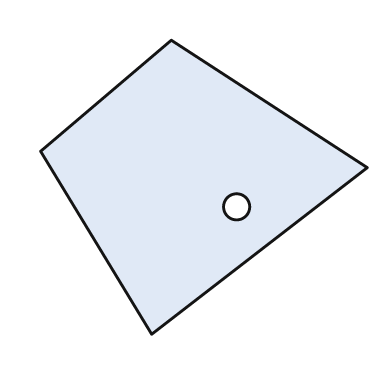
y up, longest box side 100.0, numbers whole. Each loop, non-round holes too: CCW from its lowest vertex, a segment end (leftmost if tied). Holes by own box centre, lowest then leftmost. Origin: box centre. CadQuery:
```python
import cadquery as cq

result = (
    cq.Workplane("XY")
    .moveTo(-16.0, -45.0)
    .lineTo(50.0, 6.0)
    .lineTo(-10.0, 45.0)
    .lineTo(-50.0, 11.0)
    .close()
    .moveTo(10.0, -6.0)
    .circle(4.0)
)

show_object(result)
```